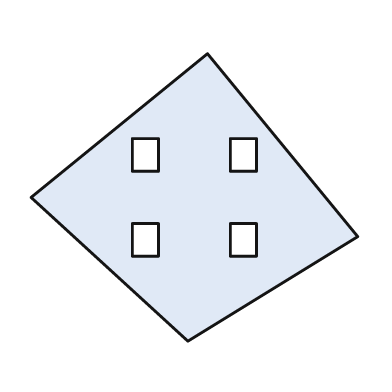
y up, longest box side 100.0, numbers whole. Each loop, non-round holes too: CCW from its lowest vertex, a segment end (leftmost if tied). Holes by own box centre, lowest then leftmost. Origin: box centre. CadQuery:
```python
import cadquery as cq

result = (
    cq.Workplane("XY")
    .moveTo(-2.0, -44.0)
    .lineTo(50.0, -12.0)
    .lineTo(4.0, 44.0)
    .lineTo(-50.0, 0.0)
    .close()
    .moveTo(-19.0, -18.0)
    .lineTo(-11.0, -18.0)
    .lineTo(-11.0, -8.0)
    .lineTo(-19.0, -8.0)
    .close()
    .moveTo(11.0, -18.0)
    .lineTo(19.0, -18.0)
    .lineTo(19.0, -8.0)
    .lineTo(11.0, -8.0)
    .close()
    .moveTo(-19.0, 8.0)
    .lineTo(-11.0, 8.0)
    .lineTo(-11.0, 18.0)
    .lineTo(-19.0, 18.0)
    .close()
    .moveTo(11.0, 8.0)
    .lineTo(19.0, 8.0)
    .lineTo(19.0, 18.0)
    .lineTo(11.0, 18.0)
    .close()
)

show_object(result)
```